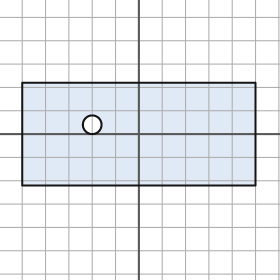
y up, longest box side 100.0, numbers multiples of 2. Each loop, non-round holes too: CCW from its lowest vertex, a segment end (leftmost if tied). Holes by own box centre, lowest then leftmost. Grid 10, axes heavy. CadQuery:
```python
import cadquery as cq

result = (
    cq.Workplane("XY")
    .moveTo(-50.0, -22.0)
    .lineTo(50.0, -22.0)
    .lineTo(50.0, 22.0)
    .lineTo(-50.0, 22.0)
    .close()
    .moveTo(-20.0, 4.0)
    .circle(4.0)
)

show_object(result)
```